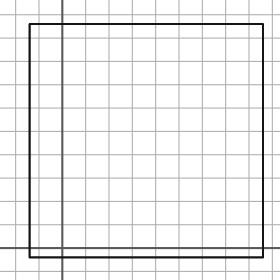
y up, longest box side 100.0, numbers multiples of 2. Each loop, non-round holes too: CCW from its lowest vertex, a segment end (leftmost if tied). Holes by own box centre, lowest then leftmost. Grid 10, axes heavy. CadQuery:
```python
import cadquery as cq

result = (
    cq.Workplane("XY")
    .moveTo(-14.0, -4.0)
    .lineTo(86.0, -4.0)
    .lineTo(86.0, 96.0)
    .lineTo(-14.0, 96.0)
    .close()
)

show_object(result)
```